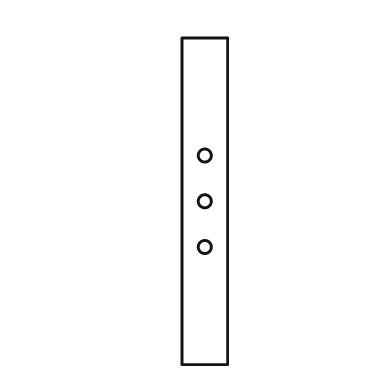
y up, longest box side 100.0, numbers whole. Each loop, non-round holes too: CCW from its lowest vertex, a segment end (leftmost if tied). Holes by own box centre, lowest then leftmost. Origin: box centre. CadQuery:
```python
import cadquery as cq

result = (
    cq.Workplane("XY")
    .moveTo(-7.0, -50.0)
    .lineTo(7.0, -50.0)
    .lineTo(7.0, 50.0)
    .lineTo(-7.0, 50.0)
    .close()
    .moveTo(0.0, -14.0)
    .circle(2.0)
    .moveTo(0.0, 0.0)
    .circle(2.0)
    .moveTo(0.0, 14.0)
    .circle(2.0)
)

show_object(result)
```